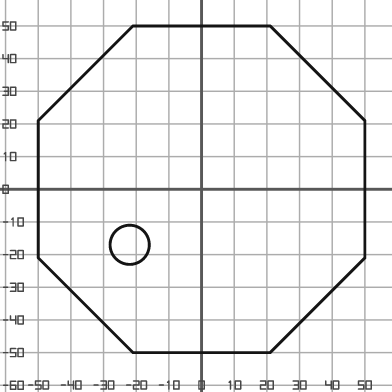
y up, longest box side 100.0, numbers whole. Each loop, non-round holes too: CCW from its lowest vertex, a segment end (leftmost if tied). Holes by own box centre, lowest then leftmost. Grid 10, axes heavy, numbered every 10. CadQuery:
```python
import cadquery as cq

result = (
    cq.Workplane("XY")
    .moveTo(-21.0, -50.0)
    .lineTo(21.0, -50.0)
    .lineTo(50.0, -21.0)
    .lineTo(50.0, 21.0)
    .lineTo(21.0, 50.0)
    .lineTo(-21.0, 50.0)
    .lineTo(-50.0, 21.0)
    .lineTo(-50.0, -21.0)
    .close()
    .moveTo(-22.0, -17.0)
    .circle(6.0)
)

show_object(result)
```